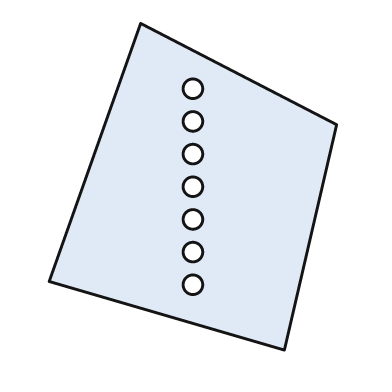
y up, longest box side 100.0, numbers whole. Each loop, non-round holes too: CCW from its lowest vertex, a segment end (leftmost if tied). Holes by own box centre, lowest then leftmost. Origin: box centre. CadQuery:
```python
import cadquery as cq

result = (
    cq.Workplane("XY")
    .moveTo(28.0, -50.0)
    .lineTo(44.0, 19.0)
    .lineTo(-16.0, 50.0)
    .lineTo(-44.0, -29.0)
    .close()
    .moveTo(0.0, -30.0)
    .circle(3.0)
    .moveTo(0.0, -20.0)
    .circle(3.0)
    .moveTo(0.0, -10.0)
    .circle(3.0)
    .moveTo(0.0, 0.0)
    .circle(3.0)
    .moveTo(0.0, 10.0)
    .circle(3.0)
    .moveTo(0.0, 20.0)
    .circle(3.0)
    .moveTo(0.0, 30.0)
    .circle(3.0)
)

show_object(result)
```